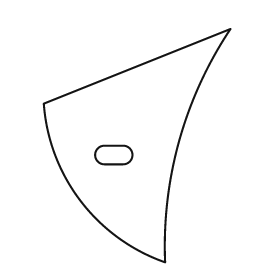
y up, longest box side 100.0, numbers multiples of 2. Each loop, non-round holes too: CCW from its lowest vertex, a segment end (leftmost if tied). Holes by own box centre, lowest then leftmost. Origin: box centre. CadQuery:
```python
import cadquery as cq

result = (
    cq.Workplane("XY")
    .moveTo(12.0, -50.0)
    .threePointArc((18.0, 2.0), (40.0, 50.0))
    .lineTo(-40.0, 18.0)
    .threePointArc((-24.0, -24.0), (12.0, -50.0))
    .close()
    .moveTo(-14.0, -8.0)
    .lineTo(-6.0, -8.0)
    .threePointArc((-2.0, -4.0), (-6.0, 0.0))
    .lineTo(-14.0, 0.0)
    .threePointArc((-18.0, -4.0), (-14.0, -8.0))
    .close()
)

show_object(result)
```